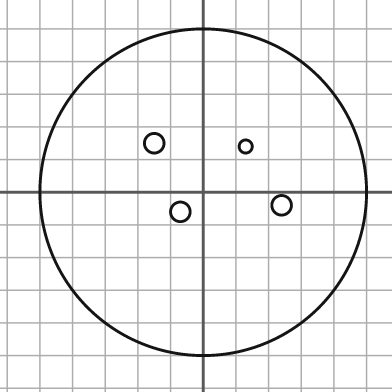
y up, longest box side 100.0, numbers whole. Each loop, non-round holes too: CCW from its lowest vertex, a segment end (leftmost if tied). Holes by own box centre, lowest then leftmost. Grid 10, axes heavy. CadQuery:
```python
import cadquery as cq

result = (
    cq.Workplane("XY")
    .moveTo(0.0, 0.0)
    .circle(50.0)
    .moveTo(-7.0, -6.0)
    .circle(3.0)
    .moveTo(24.0, -4.0)
    .circle(3.0)
    .moveTo(13.0, 14.0)
    .circle(2.0)
    .moveTo(-15.0, 15.0)
    .circle(3.0)
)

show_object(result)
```